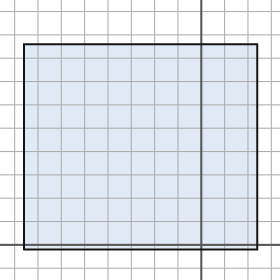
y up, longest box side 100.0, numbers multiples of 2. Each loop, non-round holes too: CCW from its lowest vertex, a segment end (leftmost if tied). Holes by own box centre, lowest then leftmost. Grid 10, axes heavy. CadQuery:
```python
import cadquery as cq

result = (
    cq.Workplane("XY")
    .moveTo(-76.0, -2.0)
    .lineTo(24.0, -2.0)
    .lineTo(24.0, 86.0)
    .lineTo(-76.0, 86.0)
    .close()
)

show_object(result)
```